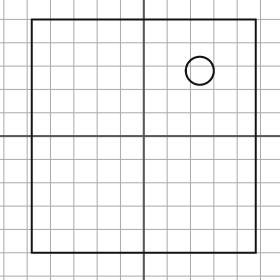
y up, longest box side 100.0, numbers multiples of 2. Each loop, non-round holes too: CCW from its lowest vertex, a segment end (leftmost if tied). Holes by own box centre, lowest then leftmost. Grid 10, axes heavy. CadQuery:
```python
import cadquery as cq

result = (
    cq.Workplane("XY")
    .moveTo(-48.0, -50.0)
    .lineTo(48.0, -50.0)
    .lineTo(48.0, 50.0)
    .lineTo(-48.0, 50.0)
    .close()
    .moveTo(24.0, 28.0)
    .circle(6.0)
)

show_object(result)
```